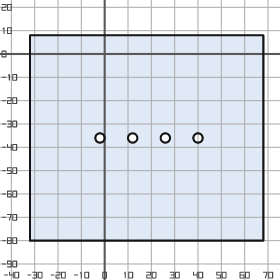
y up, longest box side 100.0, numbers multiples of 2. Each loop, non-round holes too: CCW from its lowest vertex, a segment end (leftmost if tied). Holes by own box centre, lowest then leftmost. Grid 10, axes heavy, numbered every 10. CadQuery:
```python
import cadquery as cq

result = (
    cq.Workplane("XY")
    .moveTo(-32.0, -80.0)
    .lineTo(68.0, -80.0)
    .lineTo(68.0, 8.0)
    .lineTo(-32.0, 8.0)
    .close()
    .moveTo(-2.0, -36.0)
    .circle(2.0)
    .moveTo(12.0, -36.0)
    .circle(2.0)
    .moveTo(26.0, -36.0)
    .circle(2.0)
    .moveTo(40.0, -36.0)
    .circle(2.0)
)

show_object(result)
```